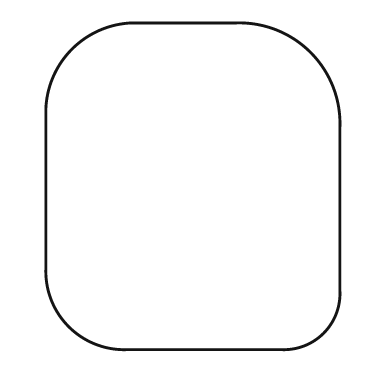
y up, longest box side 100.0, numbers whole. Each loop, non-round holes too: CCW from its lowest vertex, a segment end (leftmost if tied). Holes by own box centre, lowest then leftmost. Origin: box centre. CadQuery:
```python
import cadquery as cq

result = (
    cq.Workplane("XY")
    .moveTo(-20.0, -50.0)
    .lineTo(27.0, -50.0)
    .threePointArc((40.0, -45.0), (45.0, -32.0))
    .lineTo(45.0, 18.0)
    .threePointArc((36.0, 41.0), (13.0, 50.0))
    .lineTo(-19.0, 50.0)
    .threePointArc((-37.0, 42.0), (-45.0, 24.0))
    .lineTo(-45.0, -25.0)
    .threePointArc((-38.0, -43.0), (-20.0, -50.0))
    .close()
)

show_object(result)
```